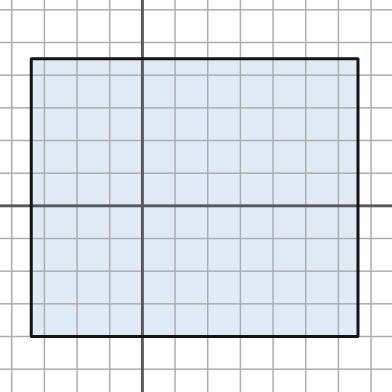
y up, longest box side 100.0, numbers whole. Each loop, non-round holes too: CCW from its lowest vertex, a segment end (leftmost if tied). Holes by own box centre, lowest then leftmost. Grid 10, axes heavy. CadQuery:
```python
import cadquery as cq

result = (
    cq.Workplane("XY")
    .moveTo(-34.0, -40.0)
    .lineTo(66.0, -40.0)
    .lineTo(66.0, 45.0)
    .lineTo(-34.0, 45.0)
    .close()
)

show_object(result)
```